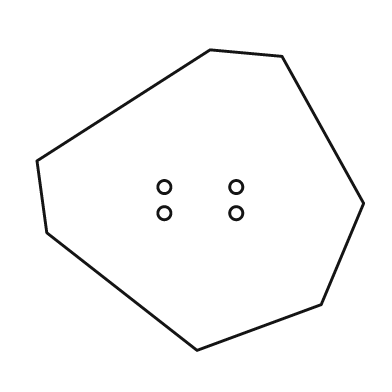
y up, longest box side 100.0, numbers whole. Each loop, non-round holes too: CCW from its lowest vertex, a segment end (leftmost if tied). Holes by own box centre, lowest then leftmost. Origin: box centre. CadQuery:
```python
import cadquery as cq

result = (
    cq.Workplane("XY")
    .moveTo(-1.0, -46.0)
    .lineTo(37.0, -32.0)
    .lineTo(50.0, -1.0)
    .lineTo(25.0, 44.0)
    .lineTo(3.0, 46.0)
    .lineTo(-50.0, 12.0)
    .lineTo(-47.0, -10.0)
    .close()
    .moveTo(-11.0, -4.0)
    .circle(2.0)
    .moveTo(11.0, -4.0)
    .circle(2.0)
    .moveTo(-11.0, 4.0)
    .circle(2.0)
    .moveTo(11.0, 4.0)
    .circle(2.0)
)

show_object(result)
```